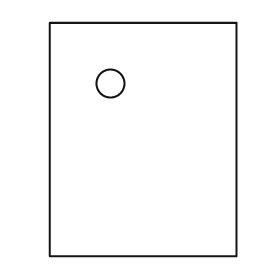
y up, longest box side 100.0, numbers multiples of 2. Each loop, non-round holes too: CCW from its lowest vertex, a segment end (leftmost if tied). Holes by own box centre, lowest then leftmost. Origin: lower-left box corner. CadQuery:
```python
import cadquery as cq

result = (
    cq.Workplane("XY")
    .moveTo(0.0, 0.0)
    .lineTo(80.0, 0.0)
    .lineTo(80.0, 100.0)
    .lineTo(0.0, 100.0)
    .close()
    .moveTo(26.0, 74.0)
    .circle(6.0)
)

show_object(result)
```